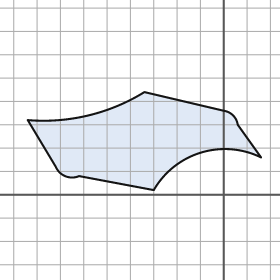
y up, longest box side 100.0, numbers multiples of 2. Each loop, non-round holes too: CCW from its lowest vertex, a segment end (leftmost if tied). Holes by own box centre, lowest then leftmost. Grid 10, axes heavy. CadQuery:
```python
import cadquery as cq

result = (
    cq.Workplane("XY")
    .moveTo(-30.0, 2.0)
    .threePointArc((-10.0, 18.0), (16.0, 16.0))
    .lineTo(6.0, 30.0)
    .threePointArc((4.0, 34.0), (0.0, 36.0))
    .lineTo(-34.0, 44.0)
    .threePointArc((-58.0, 34.0), (-84.0, 32.0))
    .lineTo(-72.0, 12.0)
    .threePointArc((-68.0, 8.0), (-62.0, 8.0))
    .close()
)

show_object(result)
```